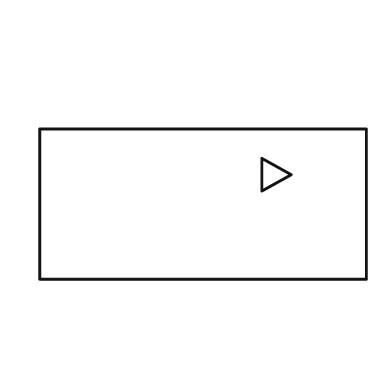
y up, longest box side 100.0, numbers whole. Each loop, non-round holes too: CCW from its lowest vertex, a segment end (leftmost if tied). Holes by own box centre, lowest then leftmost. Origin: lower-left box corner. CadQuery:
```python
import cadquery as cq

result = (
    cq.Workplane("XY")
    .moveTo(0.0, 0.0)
    .lineTo(100.0, 0.0)
    .lineTo(100.0, 46.0)
    .lineTo(0.0, 46.0)
    .close()
    .moveTo(68.0, 27.0)
    .lineTo(77.0, 32.0)
    .lineTo(68.0, 37.0)
    .close()
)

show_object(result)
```